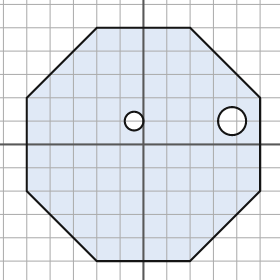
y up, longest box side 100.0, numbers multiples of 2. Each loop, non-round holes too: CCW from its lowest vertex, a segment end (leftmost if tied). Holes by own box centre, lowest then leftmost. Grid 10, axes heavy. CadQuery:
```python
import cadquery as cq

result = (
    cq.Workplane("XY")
    .moveTo(-20.0, -50.0)
    .lineTo(20.0, -50.0)
    .lineTo(50.0, -20.0)
    .lineTo(50.0, 20.0)
    .lineTo(20.0, 50.0)
    .lineTo(-20.0, 50.0)
    .lineTo(-50.0, 20.0)
    .lineTo(-50.0, -20.0)
    .close()
    .moveTo(-4.0, 10.0)
    .circle(4.0)
    .moveTo(38.0, 10.0)
    .circle(6.0)
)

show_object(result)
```